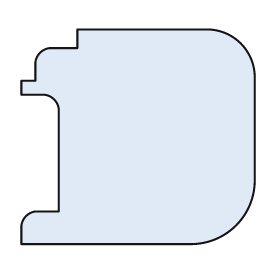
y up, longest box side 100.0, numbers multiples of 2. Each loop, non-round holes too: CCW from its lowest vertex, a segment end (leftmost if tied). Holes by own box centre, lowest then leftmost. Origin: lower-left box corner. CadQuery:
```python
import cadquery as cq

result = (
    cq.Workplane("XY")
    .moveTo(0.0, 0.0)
    .lineTo(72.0, 0.0)
    .threePointArc((92.0, 8.0), (100.0, 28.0))
    .lineTo(100.0, 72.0)
    .threePointArc((94.0, 86.0), (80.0, 92.0))
    .lineTo(24.0, 92.0)
    .lineTo(24.0, 84.0)
    .lineTo(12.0, 84.0)
    .threePointArc((8.0, 82.0), (6.0, 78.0))
    .lineTo(6.0, 70.0)
    .lineTo(0.0, 70.0)
    .lineTo(0.0, 64.0)
    .lineTo(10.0, 64.0)
    .threePointArc((14.0, 62.0), (16.0, 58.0))
    .lineTo(16.0, 14.0)
    .lineTo(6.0, 14.0)
    .threePointArc((2.0, 12.0), (0.0, 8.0))
    .close()
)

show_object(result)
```